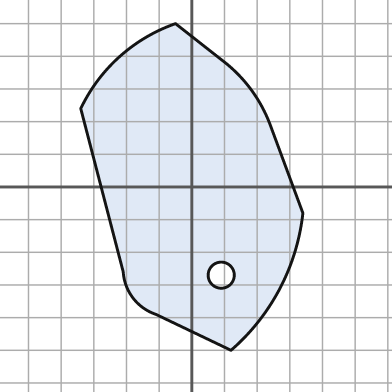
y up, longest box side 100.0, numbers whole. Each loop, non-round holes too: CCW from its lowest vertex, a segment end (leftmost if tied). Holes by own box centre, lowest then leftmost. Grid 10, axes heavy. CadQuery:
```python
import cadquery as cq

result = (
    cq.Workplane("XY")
    .moveTo(12.0, -50.0)
    .threePointArc((27.0, -31.0), (34.0, -8.0))
    .lineTo(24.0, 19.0)
    .threePointArc((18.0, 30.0), (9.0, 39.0))
    .lineTo(-5.0, 50.0)
    .threePointArc((-22.0, 40.0), (-34.0, 24.0))
    .lineTo(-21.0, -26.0)
    .threePointArc((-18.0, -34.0), (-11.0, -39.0))
    .close()
    .moveTo(9.0, -27.0)
    .circle(4.0)
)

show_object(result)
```